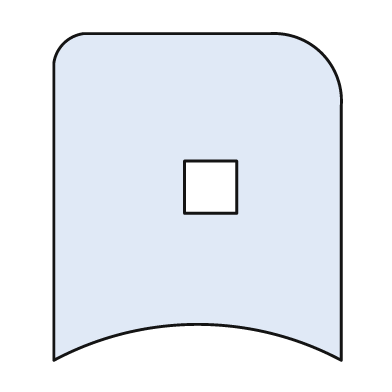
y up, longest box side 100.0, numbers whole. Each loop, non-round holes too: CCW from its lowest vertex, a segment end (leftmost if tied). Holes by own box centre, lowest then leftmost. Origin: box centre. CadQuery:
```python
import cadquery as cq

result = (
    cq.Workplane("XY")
    .moveTo(-44.0, -50.0)
    .threePointArc((0.0, -39.0), (44.0, -50.0))
    .lineTo(44.0, 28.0)
    .threePointArc((38.0, 44.0), (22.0, 50.0))
    .lineTo(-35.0, 50.0)
    .threePointArc((-41.0, 47.0), (-44.0, 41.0))
    .close()
    .moveTo(-4.0, -5.0)
    .lineTo(12.0, -5.0)
    .lineTo(12.0, 11.0)
    .lineTo(-4.0, 11.0)
    .close()
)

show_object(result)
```